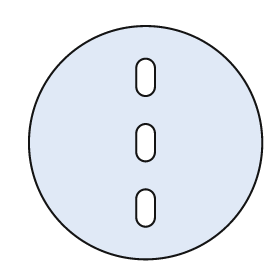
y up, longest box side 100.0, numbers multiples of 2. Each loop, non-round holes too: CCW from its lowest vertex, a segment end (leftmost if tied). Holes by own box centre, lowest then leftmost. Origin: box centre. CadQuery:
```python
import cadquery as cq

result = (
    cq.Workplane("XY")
    .moveTo(0.0, 0.0)
    .circle(50.0)
    .moveTo(-4.0, -32.0)
    .threePointArc((0.0, -36.0), (4.0, -32.0))
    .lineTo(4.0, -24.0)
    .threePointArc((0.0, -20.0), (-4.0, -24.0))
    .close()
    .moveTo(-4.0, -4.0)
    .threePointArc((0.0, -8.0), (4.0, -4.0))
    .lineTo(4.0, 4.0)
    .threePointArc((0.0, 8.0), (-4.0, 4.0))
    .close()
    .moveTo(-4.0, 24.0)
    .threePointArc((0.0, 20.0), (4.0, 24.0))
    .lineTo(4.0, 32.0)
    .threePointArc((0.0, 36.0), (-4.0, 32.0))
    .close()
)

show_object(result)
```